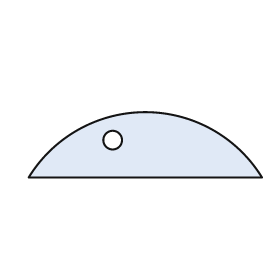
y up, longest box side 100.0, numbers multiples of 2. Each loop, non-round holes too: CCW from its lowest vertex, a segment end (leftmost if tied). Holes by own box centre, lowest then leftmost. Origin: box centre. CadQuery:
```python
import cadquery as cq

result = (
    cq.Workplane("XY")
    .moveTo(-50.0, -14.0)
    .lineTo(50.0, -14.0)
    .threePointArc((0.0, 14.0), (-50.0, -14.0))
    .close()
    .moveTo(-14.0, 2.0)
    .circle(4.0)
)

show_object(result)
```